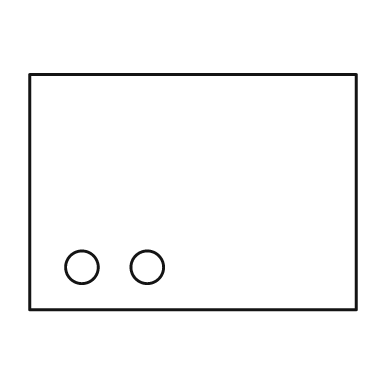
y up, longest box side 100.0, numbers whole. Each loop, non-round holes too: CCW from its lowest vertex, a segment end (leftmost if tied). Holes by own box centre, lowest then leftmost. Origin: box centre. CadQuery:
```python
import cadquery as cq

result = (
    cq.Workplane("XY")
    .moveTo(-50.0, -36.0)
    .lineTo(50.0, -36.0)
    .lineTo(50.0, 36.0)
    .lineTo(-50.0, 36.0)
    .close()
    .moveTo(-34.0, -23.0)
    .circle(5.0)
    .moveTo(-14.0, -23.0)
    .circle(5.0)
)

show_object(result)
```